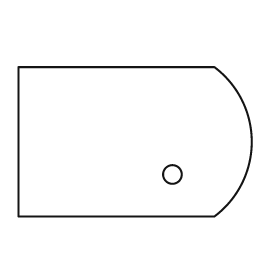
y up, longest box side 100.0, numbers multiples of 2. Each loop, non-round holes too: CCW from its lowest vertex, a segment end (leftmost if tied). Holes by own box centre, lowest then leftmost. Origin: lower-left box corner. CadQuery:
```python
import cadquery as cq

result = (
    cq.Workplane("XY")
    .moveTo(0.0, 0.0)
    .lineTo(84.0, 0.0)
    .threePointArc((100.0, 32.0), (84.0, 64.0))
    .lineTo(0.0, 64.0)
    .close()
    .moveTo(66.0, 18.0)
    .circle(4.0)
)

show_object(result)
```